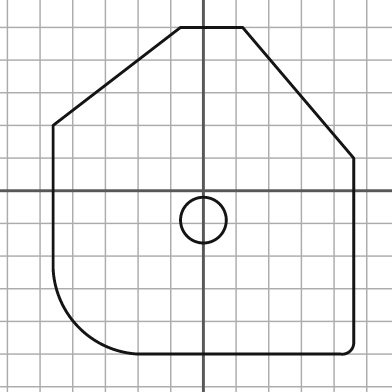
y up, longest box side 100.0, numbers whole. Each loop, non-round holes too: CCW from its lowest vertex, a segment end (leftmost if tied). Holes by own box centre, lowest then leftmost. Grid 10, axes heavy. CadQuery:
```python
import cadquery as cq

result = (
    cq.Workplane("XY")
    .moveTo(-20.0, -50.0)
    .lineTo(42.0, -50.0)
    .threePointArc((45.0, -49.0), (46.0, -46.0))
    .lineTo(46.0, 10.0)
    .lineTo(12.0, 50.0)
    .lineTo(-7.0, 50.0)
    .lineTo(-46.0, 20.0)
    .lineTo(-46.0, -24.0)
    .threePointArc((-38.0, -42.0), (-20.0, -50.0))
    .close()
    .moveTo(0.0, -9.0)
    .circle(7.0)
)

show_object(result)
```